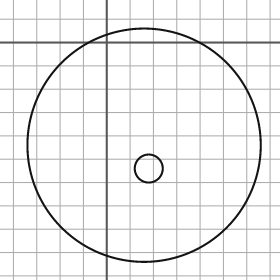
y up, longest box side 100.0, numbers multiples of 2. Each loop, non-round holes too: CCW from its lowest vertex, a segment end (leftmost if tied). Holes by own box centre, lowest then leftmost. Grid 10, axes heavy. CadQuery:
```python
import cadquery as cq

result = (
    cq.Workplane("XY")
    .moveTo(16.0, -44.0)
    .circle(50.0)
    .moveTo(18.0, -54.0)
    .circle(6.0)
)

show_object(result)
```